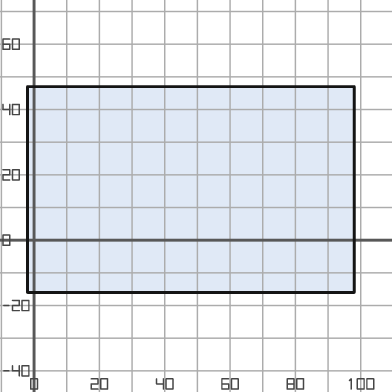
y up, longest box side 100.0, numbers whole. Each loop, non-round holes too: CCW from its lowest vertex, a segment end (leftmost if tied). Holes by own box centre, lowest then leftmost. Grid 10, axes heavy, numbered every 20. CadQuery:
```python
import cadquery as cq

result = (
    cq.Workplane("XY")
    .moveTo(-2.0, -16.0)
    .lineTo(98.0, -16.0)
    .lineTo(98.0, 47.0)
    .lineTo(-2.0, 47.0)
    .close()
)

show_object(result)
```